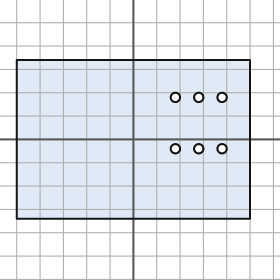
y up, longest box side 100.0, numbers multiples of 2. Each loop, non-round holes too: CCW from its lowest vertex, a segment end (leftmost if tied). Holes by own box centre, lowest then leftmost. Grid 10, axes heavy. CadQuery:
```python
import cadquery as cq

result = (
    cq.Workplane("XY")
    .moveTo(-50.0, -34.0)
    .lineTo(50.0, -34.0)
    .lineTo(50.0, 34.0)
    .lineTo(-50.0, 34.0)
    .close()
    .moveTo(18.0, -4.0)
    .circle(2.0)
    .moveTo(28.0, -4.0)
    .circle(2.0)
    .moveTo(38.0, -4.0)
    .circle(2.0)
    .moveTo(18.0, 18.0)
    .circle(2.0)
    .moveTo(28.0, 18.0)
    .circle(2.0)
    .moveTo(38.0, 18.0)
    .circle(2.0)
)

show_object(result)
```